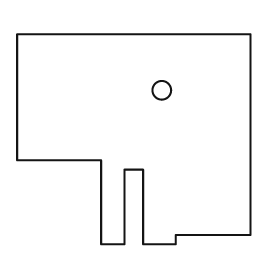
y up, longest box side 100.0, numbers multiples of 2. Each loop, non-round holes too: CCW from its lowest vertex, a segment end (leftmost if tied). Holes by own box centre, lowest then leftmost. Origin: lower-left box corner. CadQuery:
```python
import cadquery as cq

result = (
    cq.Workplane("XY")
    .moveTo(36.0, 0.0)
    .lineTo(46.0, 0.0)
    .lineTo(46.0, 32.0)
    .lineTo(54.0, 32.0)
    .lineTo(54.0, 0.0)
    .lineTo(68.0, 0.0)
    .lineTo(68.0, 4.0)
    .lineTo(100.0, 4.0)
    .lineTo(100.0, 90.0)
    .lineTo(0.0, 90.0)
    .lineTo(0.0, 36.0)
    .lineTo(36.0, 36.0)
    .close()
    .moveTo(62.0, 66.0)
    .circle(4.0)
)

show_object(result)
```